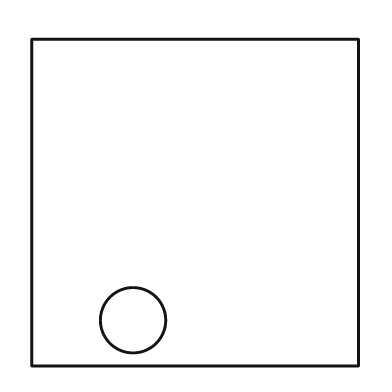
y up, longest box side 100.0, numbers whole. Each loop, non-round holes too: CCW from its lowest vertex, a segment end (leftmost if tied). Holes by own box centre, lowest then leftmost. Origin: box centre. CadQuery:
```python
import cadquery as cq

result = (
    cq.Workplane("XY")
    .moveTo(-50.0, -50.0)
    .lineTo(50.0, -50.0)
    .lineTo(50.0, 50.0)
    .lineTo(-50.0, 50.0)
    .close()
    .moveTo(-19.0, -36.0)
    .circle(10.0)
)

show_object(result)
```